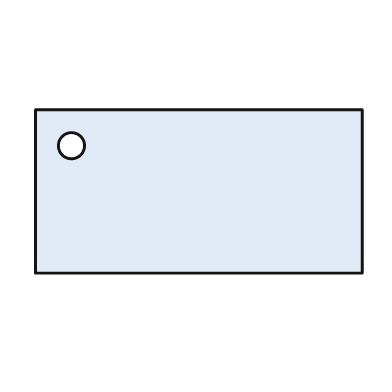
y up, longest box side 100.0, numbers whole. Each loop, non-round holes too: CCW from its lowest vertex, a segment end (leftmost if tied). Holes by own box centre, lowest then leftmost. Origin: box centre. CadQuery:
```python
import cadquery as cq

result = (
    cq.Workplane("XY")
    .moveTo(-50.0, -25.0)
    .lineTo(50.0, -25.0)
    .lineTo(50.0, 25.0)
    .lineTo(-50.0, 25.0)
    .close()
    .moveTo(-39.0, 14.0)
    .circle(4.0)
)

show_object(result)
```